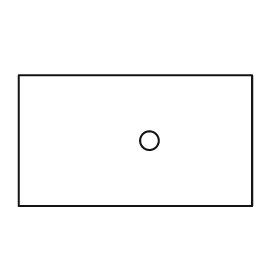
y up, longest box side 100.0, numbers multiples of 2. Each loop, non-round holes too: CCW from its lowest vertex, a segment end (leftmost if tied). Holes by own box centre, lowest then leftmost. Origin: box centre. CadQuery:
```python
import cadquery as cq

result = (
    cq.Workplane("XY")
    .moveTo(-50.0, -28.0)
    .lineTo(50.0, -28.0)
    .lineTo(50.0, 28.0)
    .lineTo(-50.0, 28.0)
    .close()
    .moveTo(6.0, 0.0)
    .circle(4.0)
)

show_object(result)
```